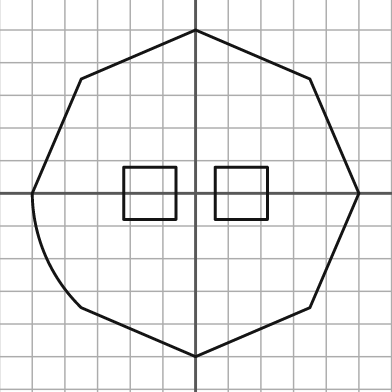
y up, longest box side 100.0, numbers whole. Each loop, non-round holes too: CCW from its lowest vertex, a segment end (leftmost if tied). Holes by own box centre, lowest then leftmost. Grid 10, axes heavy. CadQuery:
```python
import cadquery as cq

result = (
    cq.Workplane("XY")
    .moveTo(0.0, -50.0)
    .lineTo(35.0, -35.0)
    .lineTo(50.0, 0.0)
    .lineTo(35.0, 35.0)
    .lineTo(0.0, 50.0)
    .lineTo(-35.0, 35.0)
    .lineTo(-50.0, 0.0)
    .threePointArc((-46.0, -19.0), (-35.0, -35.0))
    .close()
    .moveTo(-22.0, -8.0)
    .lineTo(-6.0, -8.0)
    .lineTo(-6.0, 8.0)
    .lineTo(-22.0, 8.0)
    .close()
    .moveTo(6.0, -8.0)
    .lineTo(22.0, -8.0)
    .lineTo(22.0, 8.0)
    .lineTo(6.0, 8.0)
    .close()
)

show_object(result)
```